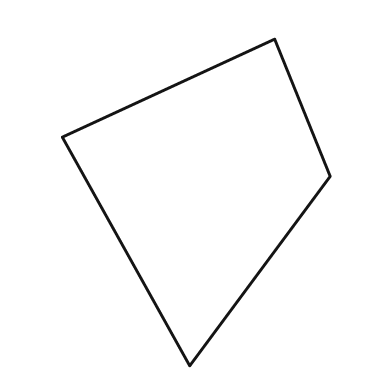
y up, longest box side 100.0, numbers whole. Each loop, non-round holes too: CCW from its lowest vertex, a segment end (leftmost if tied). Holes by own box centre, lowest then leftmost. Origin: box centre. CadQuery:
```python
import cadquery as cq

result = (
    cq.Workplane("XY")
    .moveTo(-2.0, -50.0)
    .lineTo(41.0, 8.0)
    .lineTo(24.0, 50.0)
    .lineTo(-41.0, 20.0)
    .close()
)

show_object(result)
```